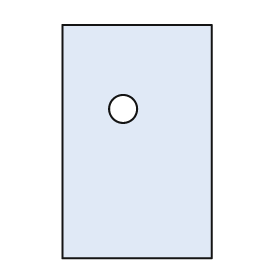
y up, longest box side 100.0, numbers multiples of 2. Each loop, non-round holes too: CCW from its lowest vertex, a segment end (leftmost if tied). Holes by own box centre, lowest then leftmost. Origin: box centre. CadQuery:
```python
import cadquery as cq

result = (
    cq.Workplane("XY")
    .moveTo(-32.0, -50.0)
    .lineTo(32.0, -50.0)
    .lineTo(32.0, 50.0)
    .lineTo(-32.0, 50.0)
    .close()
    .moveTo(-6.0, 14.0)
    .circle(6.0)
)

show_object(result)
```